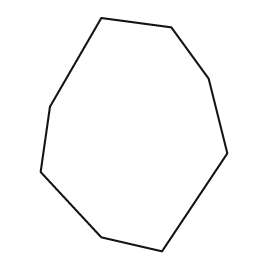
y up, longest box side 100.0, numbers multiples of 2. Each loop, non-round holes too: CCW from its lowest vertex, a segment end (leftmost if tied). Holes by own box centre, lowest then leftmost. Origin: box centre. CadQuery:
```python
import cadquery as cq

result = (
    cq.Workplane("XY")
    .moveTo(12.0, -50.0)
    .lineTo(40.0, -8.0)
    .lineTo(32.0, 24.0)
    .lineTo(16.0, 46.0)
    .lineTo(-14.0, 50.0)
    .lineTo(-36.0, 12.0)
    .lineTo(-40.0, -16.0)
    .lineTo(-14.0, -44.0)
    .close()
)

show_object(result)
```